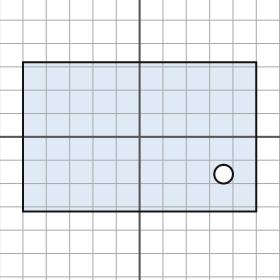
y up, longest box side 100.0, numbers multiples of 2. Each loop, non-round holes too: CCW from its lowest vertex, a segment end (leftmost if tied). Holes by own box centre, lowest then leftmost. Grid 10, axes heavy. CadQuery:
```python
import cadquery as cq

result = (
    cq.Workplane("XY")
    .moveTo(-50.0, -32.0)
    .lineTo(50.0, -32.0)
    .lineTo(50.0, 32.0)
    .lineTo(-50.0, 32.0)
    .close()
    .moveTo(36.0, -16.0)
    .circle(4.0)
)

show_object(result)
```